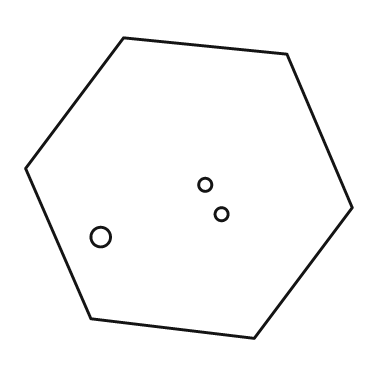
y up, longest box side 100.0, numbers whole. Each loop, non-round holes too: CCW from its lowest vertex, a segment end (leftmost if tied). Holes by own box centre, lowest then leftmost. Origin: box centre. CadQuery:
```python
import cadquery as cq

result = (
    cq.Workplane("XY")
    .moveTo(20.0, -46.0)
    .lineTo(50.0, -6.0)
    .lineTo(30.0, 41.0)
    .lineTo(-20.0, 46.0)
    .lineTo(-50.0, 6.0)
    .lineTo(-30.0, -40.0)
    .close()
    .moveTo(-27.0, -15.0)
    .circle(3.0)
    .moveTo(10.0, -8.0)
    .circle(2.0)
    .moveTo(5.0, 1.0)
    .circle(2.0)
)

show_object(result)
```